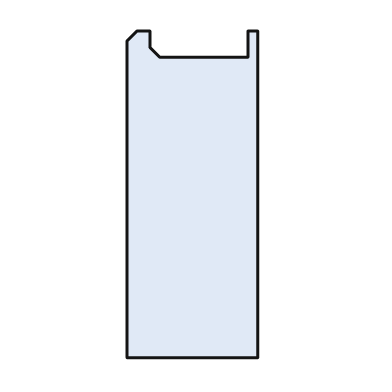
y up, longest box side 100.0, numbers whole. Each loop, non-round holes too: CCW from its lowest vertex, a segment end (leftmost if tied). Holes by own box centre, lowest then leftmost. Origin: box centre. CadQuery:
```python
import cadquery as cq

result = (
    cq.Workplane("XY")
    .moveTo(-20.0, -50.0)
    .lineTo(20.0, -50.0)
    .lineTo(20.0, 50.0)
    .lineTo(17.0, 50.0)
    .lineTo(17.0, 42.0)
    .lineTo(-10.0, 42.0)
    .lineTo(-13.0, 45.0)
    .lineTo(-13.0, 50.0)
    .lineTo(-17.0, 50.0)
    .lineTo(-20.0, 47.0)
    .close()
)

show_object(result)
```